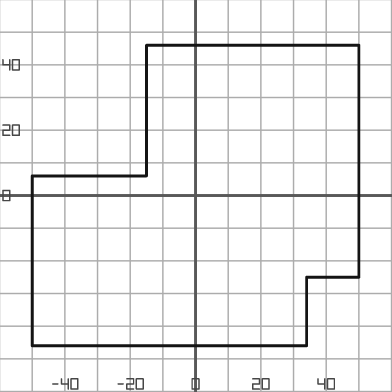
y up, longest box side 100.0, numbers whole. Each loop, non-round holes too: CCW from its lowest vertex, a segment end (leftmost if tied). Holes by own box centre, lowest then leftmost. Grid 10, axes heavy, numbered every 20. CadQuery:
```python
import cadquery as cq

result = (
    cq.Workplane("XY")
    .moveTo(-50.0, -46.0)
    .lineTo(34.0, -46.0)
    .lineTo(34.0, -25.0)
    .lineTo(50.0, -25.0)
    .lineTo(50.0, 46.0)
    .lineTo(-15.0, 46.0)
    .lineTo(-15.0, 6.0)
    .lineTo(-50.0, 6.0)
    .close()
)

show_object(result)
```